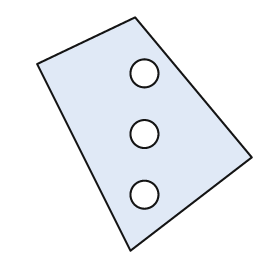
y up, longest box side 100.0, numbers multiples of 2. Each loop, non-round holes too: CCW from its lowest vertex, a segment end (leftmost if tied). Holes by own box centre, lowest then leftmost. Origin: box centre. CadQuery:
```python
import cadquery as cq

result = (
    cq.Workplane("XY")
    .moveTo(-6.0, -50.0)
    .lineTo(46.0, -10.0)
    .lineTo(-4.0, 50.0)
    .lineTo(-46.0, 30.0)
    .close()
    .moveTo(0.0, -26.0)
    .circle(6.0)
    .moveTo(0.0, 0.0)
    .circle(6.0)
    .moveTo(0.0, 26.0)
    .circle(6.0)
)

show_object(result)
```